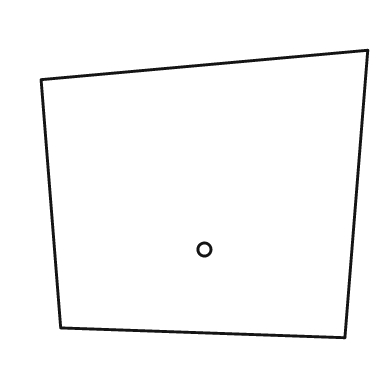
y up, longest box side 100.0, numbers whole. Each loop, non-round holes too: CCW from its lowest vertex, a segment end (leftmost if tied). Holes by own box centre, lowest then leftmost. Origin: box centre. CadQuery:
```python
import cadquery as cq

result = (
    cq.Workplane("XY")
    .moveTo(43.0, -44.0)
    .lineTo(50.0, 44.0)
    .lineTo(-50.0, 35.0)
    .lineTo(-44.0, -41.0)
    .close()
    .moveTo(0.0, -17.0)
    .circle(2.0)
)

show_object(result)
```